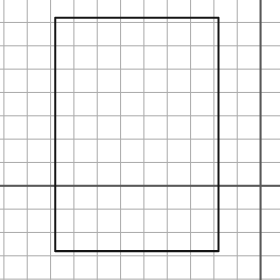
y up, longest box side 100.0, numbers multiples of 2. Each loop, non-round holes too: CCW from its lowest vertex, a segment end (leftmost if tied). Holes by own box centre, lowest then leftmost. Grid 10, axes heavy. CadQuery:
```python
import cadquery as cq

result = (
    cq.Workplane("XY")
    .moveTo(-88.0, -28.0)
    .lineTo(-18.0, -28.0)
    .lineTo(-18.0, 72.0)
    .lineTo(-88.0, 72.0)
    .close()
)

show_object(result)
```